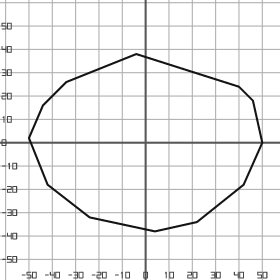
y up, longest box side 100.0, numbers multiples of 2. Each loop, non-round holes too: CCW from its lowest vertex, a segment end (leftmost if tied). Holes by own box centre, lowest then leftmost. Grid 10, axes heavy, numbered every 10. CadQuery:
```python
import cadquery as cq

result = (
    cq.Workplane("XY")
    .moveTo(4.0, -38.0)
    .lineTo(22.0, -34.0)
    .lineTo(42.0, -18.0)
    .lineTo(50.0, 0.0)
    .lineTo(46.0, 18.0)
    .lineTo(40.0, 24.0)
    .lineTo(-4.0, 38.0)
    .lineTo(-34.0, 26.0)
    .lineTo(-44.0, 16.0)
    .lineTo(-50.0, 2.0)
    .lineTo(-42.0, -18.0)
    .lineTo(-24.0, -32.0)
    .close()
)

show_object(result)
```